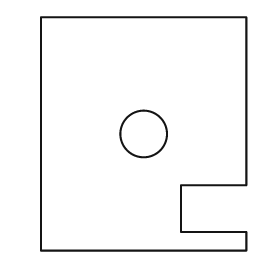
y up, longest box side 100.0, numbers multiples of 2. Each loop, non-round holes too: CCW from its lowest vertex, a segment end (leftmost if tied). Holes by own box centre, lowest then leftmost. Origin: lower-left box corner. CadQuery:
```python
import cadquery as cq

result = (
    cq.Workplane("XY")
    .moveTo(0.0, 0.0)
    .lineTo(88.0, 0.0)
    .lineTo(88.0, 8.0)
    .lineTo(60.0, 8.0)
    .lineTo(60.0, 28.0)
    .lineTo(88.0, 28.0)
    .lineTo(88.0, 100.0)
    .lineTo(0.0, 100.0)
    .close()
    .moveTo(44.0, 50.0)
    .circle(10.0)
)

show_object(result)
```